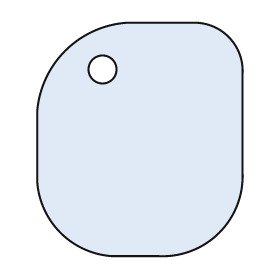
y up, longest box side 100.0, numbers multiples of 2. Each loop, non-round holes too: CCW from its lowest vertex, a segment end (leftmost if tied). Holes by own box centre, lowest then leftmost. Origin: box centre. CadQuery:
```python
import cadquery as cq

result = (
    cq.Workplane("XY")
    .moveTo(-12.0, -50.0)
    .lineTo(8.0, -50.0)
    .threePointArc((34.0, -40.0), (44.0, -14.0))
    .lineTo(44.0, 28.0)
    .threePointArc((38.0, 44.0), (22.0, 50.0))
    .lineTo(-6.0, 50.0)
    .threePointArc((-32.0, 38.0), (-44.0, 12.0))
    .lineTo(-44.0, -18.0)
    .threePointArc((-34.0, -40.0), (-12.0, -50.0))
    .close()
    .moveTo(-16.0, 30.0)
    .circle(6.0)
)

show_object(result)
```